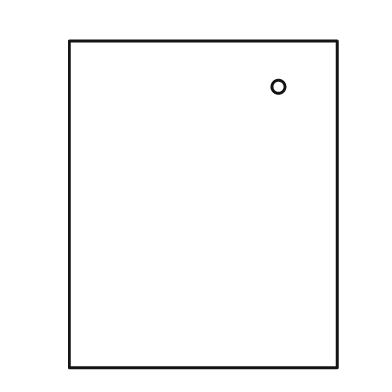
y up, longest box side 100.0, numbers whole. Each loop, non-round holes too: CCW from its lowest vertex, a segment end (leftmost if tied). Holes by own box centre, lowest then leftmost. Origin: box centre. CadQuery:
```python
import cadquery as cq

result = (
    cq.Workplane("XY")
    .moveTo(-41.0, -50.0)
    .lineTo(41.0, -50.0)
    .lineTo(41.0, 50.0)
    .lineTo(-41.0, 50.0)
    .close()
    .moveTo(23.0, 36.0)
    .circle(2.0)
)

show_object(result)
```